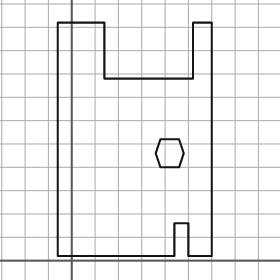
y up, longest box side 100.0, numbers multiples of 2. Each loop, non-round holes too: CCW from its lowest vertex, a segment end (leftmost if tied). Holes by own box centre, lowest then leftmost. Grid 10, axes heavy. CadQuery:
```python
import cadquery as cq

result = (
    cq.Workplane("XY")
    .moveTo(-6.0, 2.0)
    .lineTo(44.0, 2.0)
    .lineTo(44.0, 16.0)
    .lineTo(50.0, 16.0)
    .lineTo(50.0, 2.0)
    .lineTo(60.0, 2.0)
    .lineTo(60.0, 102.0)
    .lineTo(52.0, 102.0)
    .lineTo(52.0, 78.0)
    .lineTo(14.0, 78.0)
    .lineTo(14.0, 102.0)
    .lineTo(-6.0, 102.0)
    .close()
    .moveTo(38.0, 40.0)
    .lineTo(46.0, 40.0)
    .lineTo(48.0, 46.0)
    .lineTo(46.0, 52.0)
    .lineTo(38.0, 52.0)
    .lineTo(36.0, 46.0)
    .close()
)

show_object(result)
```